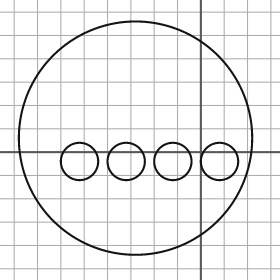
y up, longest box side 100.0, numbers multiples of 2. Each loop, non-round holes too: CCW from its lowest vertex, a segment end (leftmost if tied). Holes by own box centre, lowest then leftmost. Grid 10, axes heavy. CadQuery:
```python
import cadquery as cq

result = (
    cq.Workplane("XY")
    .moveTo(-28.0, 6.0)
    .circle(50.0)
    .moveTo(-52.0, -4.0)
    .circle(8.0)
    .moveTo(-32.0, -4.0)
    .circle(8.0)
    .moveTo(-12.0, -4.0)
    .circle(8.0)
    .moveTo(8.0, -4.0)
    .circle(8.0)
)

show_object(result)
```